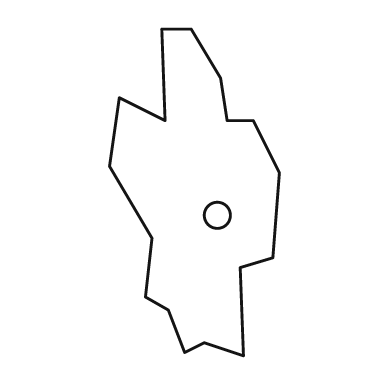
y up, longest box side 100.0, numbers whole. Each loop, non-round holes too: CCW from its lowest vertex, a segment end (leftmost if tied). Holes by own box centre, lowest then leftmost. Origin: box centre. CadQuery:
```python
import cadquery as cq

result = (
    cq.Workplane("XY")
    .moveTo(15.0, -50.0)
    .lineTo(14.0, -23.0)
    .lineTo(24.0, -20.0)
    .lineTo(26.0, 6.0)
    .lineTo(18.0, 22.0)
    .lineTo(10.0, 22.0)
    .lineTo(8.0, 35.0)
    .lineTo(-1.0, 50.0)
    .lineTo(-10.0, 50.0)
    .lineTo(-9.0, 22.0)
    .lineTo(-23.0, 29.0)
    .lineTo(-26.0, 8.0)
    .lineTo(-13.0, -14.0)
    .lineTo(-15.0, -32.0)
    .lineTo(-8.0, -36.0)
    .lineTo(-3.0, -49.0)
    .lineTo(3.0, -46.0)
    .close()
    .moveTo(7.0, -7.0)
    .circle(4.0)
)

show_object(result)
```